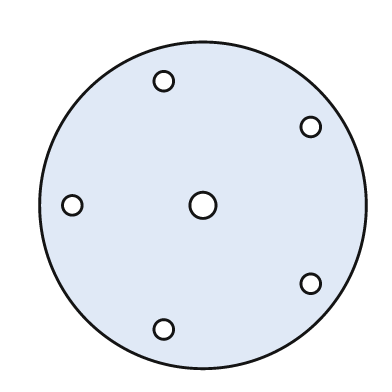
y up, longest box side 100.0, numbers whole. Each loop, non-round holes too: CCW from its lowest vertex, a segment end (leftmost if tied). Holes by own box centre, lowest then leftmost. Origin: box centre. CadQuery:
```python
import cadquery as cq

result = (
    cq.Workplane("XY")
    .moveTo(0.0, 0.0)
    .circle(50.0)
    .moveTo(-12.0, -38.0)
    .circle(3.0)
    .moveTo(33.0, -24.0)
    .circle(3.0)
    .moveTo(-40.0, 0.0)
    .circle(3.0)
    .moveTo(0.0, 0.0)
    .circle(4.0)
    .moveTo(33.0, 24.0)
    .circle(3.0)
    .moveTo(-12.0, 38.0)
    .circle(3.0)
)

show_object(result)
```